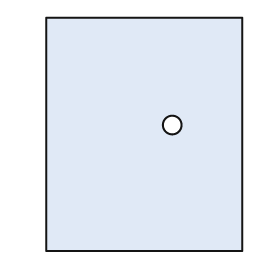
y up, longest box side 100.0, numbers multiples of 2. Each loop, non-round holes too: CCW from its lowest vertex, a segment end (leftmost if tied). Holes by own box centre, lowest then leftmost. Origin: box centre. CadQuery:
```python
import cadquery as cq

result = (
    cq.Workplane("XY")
    .moveTo(-42.0, -50.0)
    .lineTo(42.0, -50.0)
    .lineTo(42.0, 50.0)
    .lineTo(-42.0, 50.0)
    .close()
    .moveTo(12.0, 4.0)
    .circle(4.0)
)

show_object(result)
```